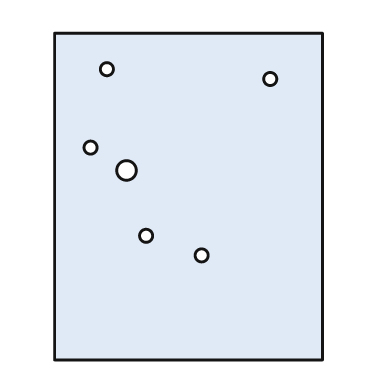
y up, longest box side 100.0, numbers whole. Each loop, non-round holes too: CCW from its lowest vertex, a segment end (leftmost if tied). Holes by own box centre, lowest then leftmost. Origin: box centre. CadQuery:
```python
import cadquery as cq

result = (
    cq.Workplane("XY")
    .moveTo(-41.0, -50.0)
    .lineTo(41.0, -50.0)
    .lineTo(41.0, 50.0)
    .lineTo(-41.0, 50.0)
    .close()
    .moveTo(4.0, -18.0)
    .circle(2.0)
    .moveTo(-13.0, -12.0)
    .circle(2.0)
    .moveTo(-19.0, 8.0)
    .circle(3.0)
    .moveTo(-30.0, 15.0)
    .circle(2.0)
    .moveTo(25.0, 36.0)
    .circle(2.0)
    .moveTo(-25.0, 39.0)
    .circle(2.0)
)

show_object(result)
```